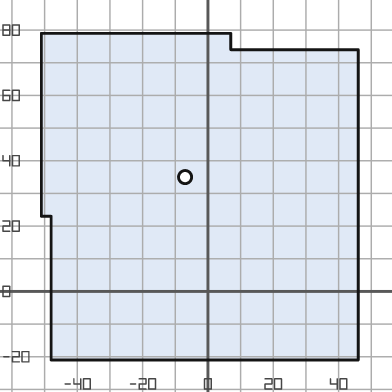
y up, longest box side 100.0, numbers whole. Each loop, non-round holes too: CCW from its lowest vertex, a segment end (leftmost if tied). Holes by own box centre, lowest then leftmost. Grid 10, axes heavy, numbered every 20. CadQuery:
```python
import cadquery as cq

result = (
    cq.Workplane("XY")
    .moveTo(-48.0, -21.0)
    .lineTo(46.0, -21.0)
    .lineTo(46.0, 74.0)
    .lineTo(7.0, 74.0)
    .lineTo(7.0, 79.0)
    .lineTo(-51.0, 79.0)
    .lineTo(-51.0, 23.0)
    .lineTo(-48.0, 23.0)
    .close()
    .moveTo(-7.0, 35.0)
    .circle(2.0)
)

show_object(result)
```